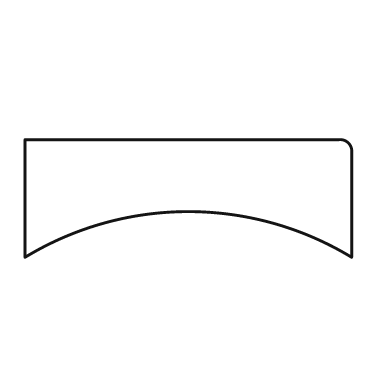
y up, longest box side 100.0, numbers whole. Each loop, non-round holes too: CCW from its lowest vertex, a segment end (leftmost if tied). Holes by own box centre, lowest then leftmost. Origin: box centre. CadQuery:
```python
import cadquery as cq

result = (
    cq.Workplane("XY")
    .moveTo(-50.0, -18.0)
    .threePointArc((0.0, -4.0), (50.0, -18.0))
    .lineTo(50.0, 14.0)
    .threePointArc((49.0, 17.0), (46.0, 18.0))
    .lineTo(-50.0, 18.0)
    .close()
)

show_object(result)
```